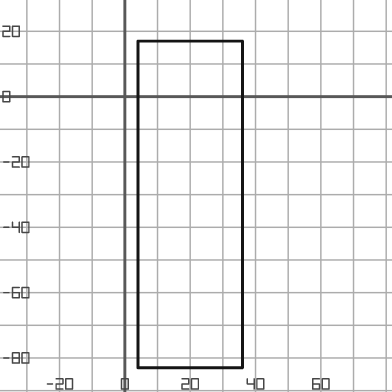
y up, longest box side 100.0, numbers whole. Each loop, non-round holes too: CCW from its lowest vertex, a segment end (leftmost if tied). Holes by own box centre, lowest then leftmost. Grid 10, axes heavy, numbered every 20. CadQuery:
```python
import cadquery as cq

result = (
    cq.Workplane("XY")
    .moveTo(4.0, -83.0)
    .lineTo(36.0, -83.0)
    .lineTo(36.0, 17.0)
    .lineTo(4.0, 17.0)
    .close()
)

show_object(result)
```